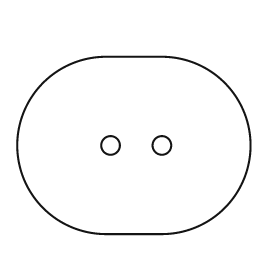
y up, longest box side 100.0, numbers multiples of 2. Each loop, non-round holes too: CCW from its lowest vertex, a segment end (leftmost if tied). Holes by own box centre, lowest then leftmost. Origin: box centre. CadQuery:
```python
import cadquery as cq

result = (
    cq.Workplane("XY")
    .moveTo(-12.0, -38.0)
    .lineTo(12.0, -38.0)
    .threePointArc((50.0, 0.0), (12.0, 38.0))
    .lineTo(-12.0, 38.0)
    .threePointArc((-50.0, 0.0), (-12.0, -38.0))
    .close()
    .moveTo(-10.0, 0.0)
    .circle(4.0)
    .moveTo(12.0, 0.0)
    .circle(4.0)
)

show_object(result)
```